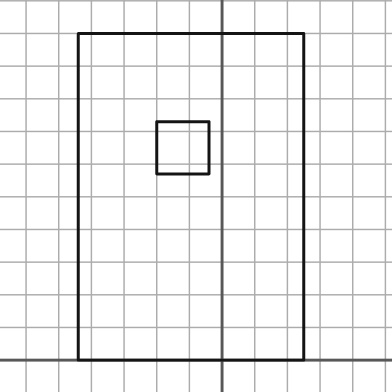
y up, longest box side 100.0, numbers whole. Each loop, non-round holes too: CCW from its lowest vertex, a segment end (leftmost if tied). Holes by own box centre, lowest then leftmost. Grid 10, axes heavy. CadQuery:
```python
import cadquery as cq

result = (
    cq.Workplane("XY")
    .moveTo(-44.0, 0.0)
    .lineTo(25.0, 0.0)
    .lineTo(25.0, 100.0)
    .lineTo(-44.0, 100.0)
    .close()
    .moveTo(-20.0, 57.0)
    .lineTo(-4.0, 57.0)
    .lineTo(-4.0, 73.0)
    .lineTo(-20.0, 73.0)
    .close()
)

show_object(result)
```